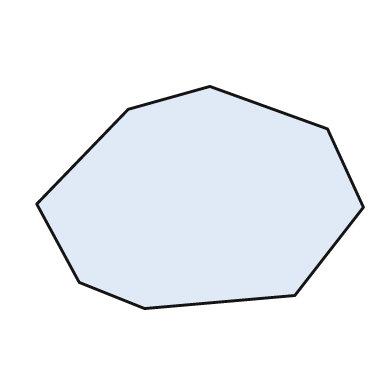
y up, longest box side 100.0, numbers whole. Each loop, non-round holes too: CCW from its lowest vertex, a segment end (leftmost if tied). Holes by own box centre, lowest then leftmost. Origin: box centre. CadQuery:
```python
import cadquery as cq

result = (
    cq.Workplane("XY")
    .moveTo(-17.0, -34.0)
    .lineTo(29.0, -30.0)
    .lineTo(50.0, -3.0)
    .lineTo(39.0, 21.0)
    .lineTo(3.0, 34.0)
    .lineTo(-22.0, 27.0)
    .lineTo(-50.0, -2.0)
    .lineTo(-37.0, -26.0)
    .close()
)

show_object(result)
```